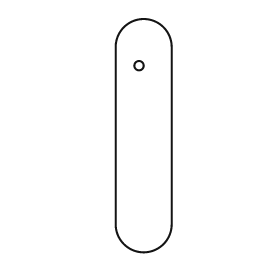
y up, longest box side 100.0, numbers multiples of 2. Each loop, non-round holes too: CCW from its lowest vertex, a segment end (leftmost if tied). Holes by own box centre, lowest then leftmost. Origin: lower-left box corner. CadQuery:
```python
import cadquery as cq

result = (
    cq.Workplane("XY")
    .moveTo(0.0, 12.0)
    .threePointArc((12.0, 0.0), (24.0, 12.0))
    .lineTo(24.0, 88.0)
    .threePointArc((12.0, 100.0), (0.0, 88.0))
    .close()
    .moveTo(10.0, 80.0)
    .circle(2.0)
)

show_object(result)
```